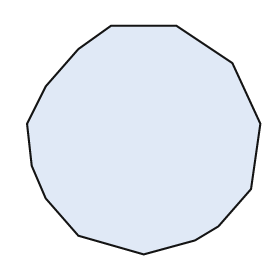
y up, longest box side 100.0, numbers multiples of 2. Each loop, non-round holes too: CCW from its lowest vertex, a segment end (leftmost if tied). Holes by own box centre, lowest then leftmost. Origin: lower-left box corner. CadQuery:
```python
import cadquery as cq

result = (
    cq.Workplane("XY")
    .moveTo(50.0, 0.0)
    .lineTo(72.0, 6.0)
    .lineTo(82.0, 12.0)
    .lineTo(96.0, 28.0)
    .lineTo(100.0, 56.0)
    .lineTo(88.0, 82.0)
    .lineTo(64.0, 98.0)
    .lineTo(36.0, 98.0)
    .lineTo(22.0, 88.0)
    .lineTo(8.0, 72.0)
    .lineTo(0.0, 56.0)
    .lineTo(2.0, 38.0)
    .lineTo(8.0, 24.0)
    .lineTo(22.0, 8.0)
    .close()
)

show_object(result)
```